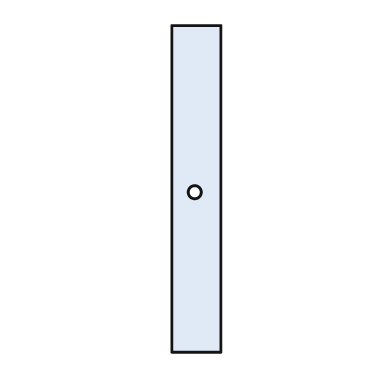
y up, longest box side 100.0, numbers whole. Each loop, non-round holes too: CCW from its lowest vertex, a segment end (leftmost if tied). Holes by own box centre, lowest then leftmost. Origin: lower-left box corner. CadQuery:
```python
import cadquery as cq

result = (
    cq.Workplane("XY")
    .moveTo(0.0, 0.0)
    .lineTo(15.0, 0.0)
    .lineTo(15.0, 100.0)
    .lineTo(0.0, 100.0)
    .close()
    .moveTo(7.0, 49.0)
    .circle(2.0)
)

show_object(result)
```